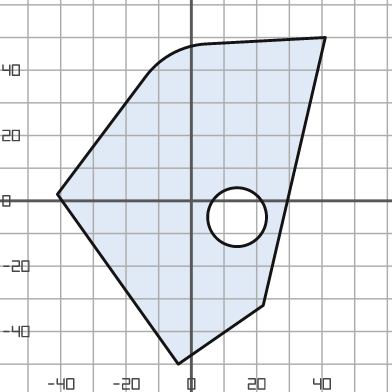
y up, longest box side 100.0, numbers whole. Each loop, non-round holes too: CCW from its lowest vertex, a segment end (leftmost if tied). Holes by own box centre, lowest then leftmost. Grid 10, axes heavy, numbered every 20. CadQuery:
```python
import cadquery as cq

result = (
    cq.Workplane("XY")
    .moveTo(-4.0, -50.0)
    .lineTo(22.0, -32.0)
    .lineTo(41.0, 50.0)
    .lineTo(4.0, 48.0)
    .threePointArc((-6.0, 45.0), (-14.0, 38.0))
    .lineTo(-41.0, 2.0)
    .close()
    .moveTo(14.0, -5.0)
    .circle(9.0)
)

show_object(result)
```